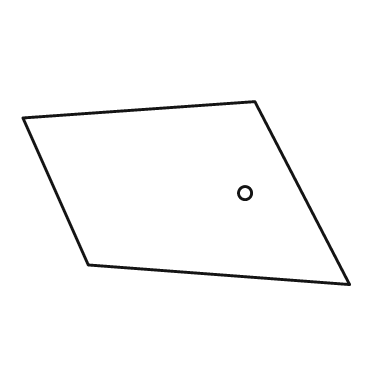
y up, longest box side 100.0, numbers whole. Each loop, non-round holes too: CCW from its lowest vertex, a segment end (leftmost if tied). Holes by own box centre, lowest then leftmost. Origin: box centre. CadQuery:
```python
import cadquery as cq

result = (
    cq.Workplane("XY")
    .moveTo(50.0, -28.0)
    .lineTo(21.0, 28.0)
    .lineTo(-50.0, 23.0)
    .lineTo(-30.0, -22.0)
    .close()
    .moveTo(18.0, 0.0)
    .circle(2.0)
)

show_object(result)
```